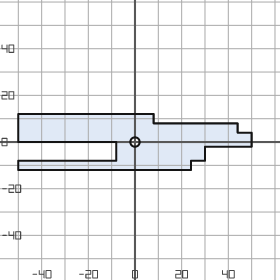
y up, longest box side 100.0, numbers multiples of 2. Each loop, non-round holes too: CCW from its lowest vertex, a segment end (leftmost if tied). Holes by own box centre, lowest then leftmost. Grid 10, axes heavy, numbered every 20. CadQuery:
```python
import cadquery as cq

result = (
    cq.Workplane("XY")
    .moveTo(-50.0, -12.0)
    .lineTo(24.0, -12.0)
    .lineTo(24.0, -8.0)
    .lineTo(30.0, -8.0)
    .lineTo(30.0, -2.0)
    .lineTo(50.0, -2.0)
    .lineTo(50.0, 4.0)
    .lineTo(44.0, 4.0)
    .lineTo(44.0, 8.0)
    .lineTo(8.0, 8.0)
    .lineTo(8.0, 12.0)
    .lineTo(-50.0, 12.0)
    .lineTo(-50.0, 0.0)
    .lineTo(-8.0, 0.0)
    .lineTo(-8.0, -8.0)
    .lineTo(-50.0, -8.0)
    .close()
    .moveTo(0.0, 0.0)
    .circle(2.0)
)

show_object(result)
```